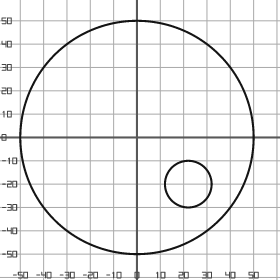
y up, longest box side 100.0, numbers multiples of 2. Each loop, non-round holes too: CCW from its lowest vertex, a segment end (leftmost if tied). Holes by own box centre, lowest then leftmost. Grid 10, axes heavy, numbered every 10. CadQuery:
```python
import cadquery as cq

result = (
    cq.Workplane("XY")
    .moveTo(0.0, 0.0)
    .circle(50.0)
    .moveTo(22.0, -20.0)
    .circle(10.0)
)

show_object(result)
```